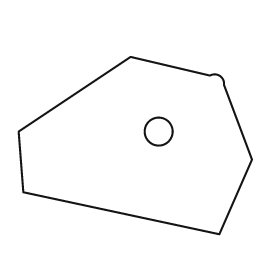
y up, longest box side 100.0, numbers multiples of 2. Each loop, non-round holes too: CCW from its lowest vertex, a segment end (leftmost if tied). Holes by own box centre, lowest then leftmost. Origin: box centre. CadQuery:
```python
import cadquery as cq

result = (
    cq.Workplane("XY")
    .moveTo(36.0, -38.0)
    .lineTo(50.0, -6.0)
    .lineTo(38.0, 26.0)
    .threePointArc((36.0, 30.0), (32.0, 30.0))
    .lineTo(-2.0, 38.0)
    .lineTo(-50.0, 6.0)
    .lineTo(-48.0, -20.0)
    .close()
    .moveTo(10.0, 6.0)
    .circle(6.0)
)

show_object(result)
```